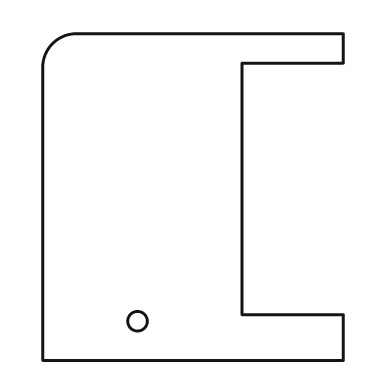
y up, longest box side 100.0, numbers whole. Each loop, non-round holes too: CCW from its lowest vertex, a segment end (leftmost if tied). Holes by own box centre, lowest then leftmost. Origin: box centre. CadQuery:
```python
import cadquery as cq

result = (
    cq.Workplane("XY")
    .moveTo(-46.0, -50.0)
    .lineTo(46.0, -50.0)
    .lineTo(46.0, -36.0)
    .lineTo(15.0, -36.0)
    .lineTo(15.0, 41.0)
    .lineTo(46.0, 41.0)
    .lineTo(46.0, 50.0)
    .lineTo(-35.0, 50.0)
    .threePointArc((-43.0, 47.0), (-46.0, 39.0))
    .close()
    .moveTo(-17.0, -38.0)
    .circle(3.0)
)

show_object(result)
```